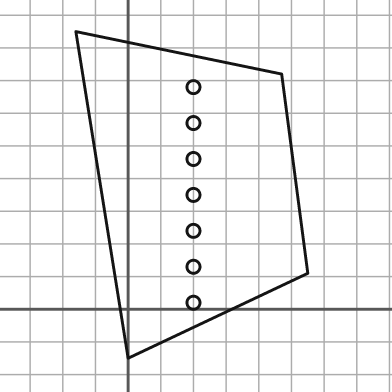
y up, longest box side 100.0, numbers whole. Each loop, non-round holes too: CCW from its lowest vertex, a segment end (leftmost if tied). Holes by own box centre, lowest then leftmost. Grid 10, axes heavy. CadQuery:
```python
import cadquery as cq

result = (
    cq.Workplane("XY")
    .moveTo(0.0, -15.0)
    .lineTo(55.0, 11.0)
    .lineTo(47.0, 72.0)
    .lineTo(-16.0, 85.0)
    .close()
    .moveTo(20.0, 2.0)
    .circle(2.0)
    .moveTo(20.0, 13.0)
    .circle(2.0)
    .moveTo(20.0, 24.0)
    .circle(2.0)
    .moveTo(20.0, 35.0)
    .circle(2.0)
    .moveTo(20.0, 46.0)
    .circle(2.0)
    .moveTo(20.0, 57.0)
    .circle(2.0)
    .moveTo(20.0, 68.0)
    .circle(2.0)
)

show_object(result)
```